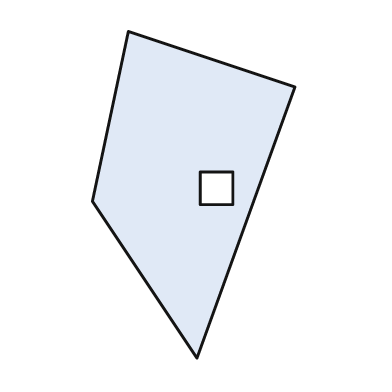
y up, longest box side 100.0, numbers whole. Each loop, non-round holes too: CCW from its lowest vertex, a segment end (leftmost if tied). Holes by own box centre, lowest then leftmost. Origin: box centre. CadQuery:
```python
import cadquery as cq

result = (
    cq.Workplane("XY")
    .moveTo(1.0, -50.0)
    .lineTo(31.0, 33.0)
    .lineTo(-20.0, 50.0)
    .lineTo(-31.0, -2.0)
    .close()
    .moveTo(2.0, -3.0)
    .lineTo(12.0, -3.0)
    .lineTo(12.0, 7.0)
    .lineTo(2.0, 7.0)
    .close()
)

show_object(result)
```